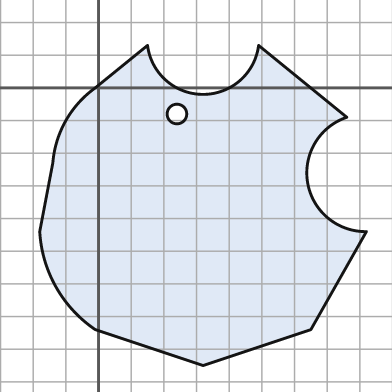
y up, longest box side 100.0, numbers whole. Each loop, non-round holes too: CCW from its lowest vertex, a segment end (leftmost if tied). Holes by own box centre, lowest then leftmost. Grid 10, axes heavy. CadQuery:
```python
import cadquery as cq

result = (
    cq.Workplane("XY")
    .moveTo(32.0, -85.0)
    .lineTo(65.0, -74.0)
    .lineTo(82.0, -44.0)
    .threePointArc((64.0, -29.0), (76.0, -9.0))
    .lineTo(49.0, 13.0)
    .threePointArc((32.0, -2.0), (15.0, 13.0))
    .lineTo(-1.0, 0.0)
    .threePointArc((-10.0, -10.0), (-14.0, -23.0))
    .lineTo(-18.0, -44.0)
    .threePointArc((-13.0, -61.0), (-1.0, -74.0))
    .close()
    .moveTo(24.0, -8.0)
    .circle(3.0)
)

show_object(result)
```